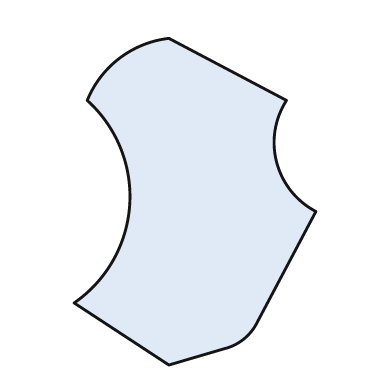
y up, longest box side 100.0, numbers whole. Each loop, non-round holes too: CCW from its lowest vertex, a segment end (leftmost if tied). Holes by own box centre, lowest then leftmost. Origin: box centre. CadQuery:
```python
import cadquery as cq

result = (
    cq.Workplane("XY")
    .moveTo(-8.0, -50.0)
    .lineTo(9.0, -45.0)
    .threePointArc((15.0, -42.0), (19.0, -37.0))
    .lineTo(37.0, -3.0)
    .threePointArc((25.0, 12.0), (28.0, 31.0))
    .lineTo(-8.0, 50.0)
    .threePointArc((-23.0, 44.0), (-33.0, 31.0))
    .threePointArc((-20.0, -1.0), (-37.0, -31.0))
    .close()
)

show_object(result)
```